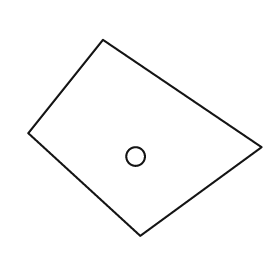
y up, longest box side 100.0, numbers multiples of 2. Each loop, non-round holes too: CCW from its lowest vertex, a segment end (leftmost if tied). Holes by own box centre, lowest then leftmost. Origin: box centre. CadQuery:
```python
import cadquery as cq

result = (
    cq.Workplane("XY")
    .moveTo(-2.0, -42.0)
    .lineTo(50.0, -4.0)
    .lineTo(-18.0, 42.0)
    .lineTo(-50.0, 2.0)
    .close()
    .moveTo(-4.0, -8.0)
    .circle(4.0)
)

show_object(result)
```